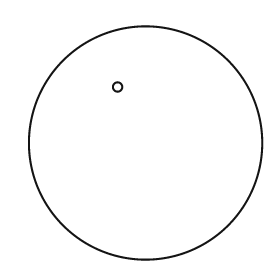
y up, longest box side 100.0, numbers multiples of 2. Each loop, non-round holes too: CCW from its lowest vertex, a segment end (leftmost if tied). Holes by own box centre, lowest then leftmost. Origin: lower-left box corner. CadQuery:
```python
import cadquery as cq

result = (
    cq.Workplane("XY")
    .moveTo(50.0, 50.0)
    .circle(50.0)
    .moveTo(38.0, 74.0)
    .circle(2.0)
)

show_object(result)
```